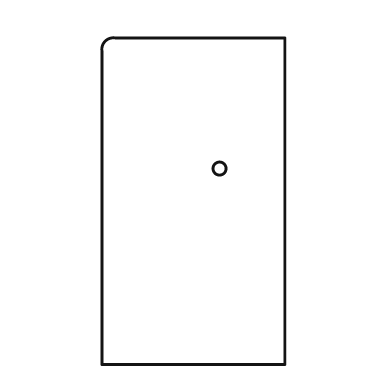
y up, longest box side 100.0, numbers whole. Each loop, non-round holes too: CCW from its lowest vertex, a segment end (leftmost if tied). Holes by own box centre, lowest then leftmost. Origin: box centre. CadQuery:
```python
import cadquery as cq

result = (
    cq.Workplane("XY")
    .moveTo(-28.0, -50.0)
    .lineTo(28.0, -50.0)
    .lineTo(28.0, 50.0)
    .lineTo(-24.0, 50.0)
    .threePointArc((-27.0, 49.0), (-28.0, 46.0))
    .close()
    .moveTo(8.0, 10.0)
    .circle(2.0)
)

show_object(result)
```